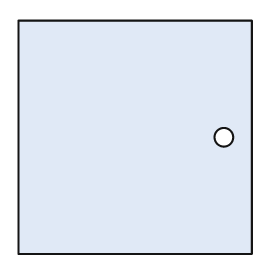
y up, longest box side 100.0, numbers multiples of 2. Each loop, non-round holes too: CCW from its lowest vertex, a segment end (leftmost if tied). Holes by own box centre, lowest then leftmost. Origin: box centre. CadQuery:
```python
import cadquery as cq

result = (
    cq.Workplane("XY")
    .moveTo(-50.0, -50.0)
    .lineTo(50.0, -50.0)
    .lineTo(50.0, 50.0)
    .lineTo(-50.0, 50.0)
    .close()
    .moveTo(38.0, 0.0)
    .circle(4.0)
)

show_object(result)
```